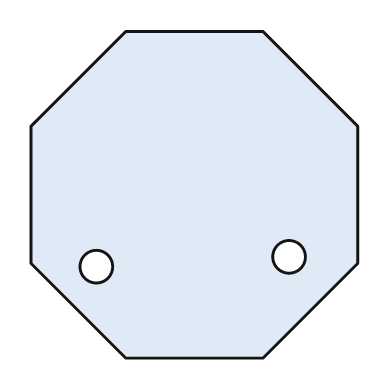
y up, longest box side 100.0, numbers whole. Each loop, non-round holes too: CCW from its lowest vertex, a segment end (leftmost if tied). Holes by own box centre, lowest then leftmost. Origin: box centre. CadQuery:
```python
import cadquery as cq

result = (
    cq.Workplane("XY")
    .moveTo(-21.0, -50.0)
    .lineTo(21.0, -50.0)
    .lineTo(50.0, -21.0)
    .lineTo(50.0, 21.0)
    .lineTo(21.0, 50.0)
    .lineTo(-21.0, 50.0)
    .lineTo(-50.0, 21.0)
    .lineTo(-50.0, -21.0)
    .close()
    .moveTo(-30.0, -22.0)
    .circle(5.0)
    .moveTo(29.0, -19.0)
    .circle(5.0)
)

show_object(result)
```